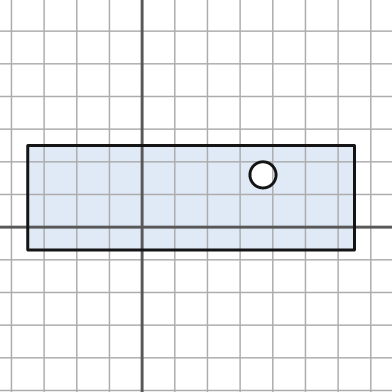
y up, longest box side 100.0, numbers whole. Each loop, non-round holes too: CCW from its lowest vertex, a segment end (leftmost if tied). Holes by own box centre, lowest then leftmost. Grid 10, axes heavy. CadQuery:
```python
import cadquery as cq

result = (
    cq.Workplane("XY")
    .moveTo(-35.0, -7.0)
    .lineTo(65.0, -7.0)
    .lineTo(65.0, 25.0)
    .lineTo(-35.0, 25.0)
    .close()
    .moveTo(37.0, 16.0)
    .circle(4.0)
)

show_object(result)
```